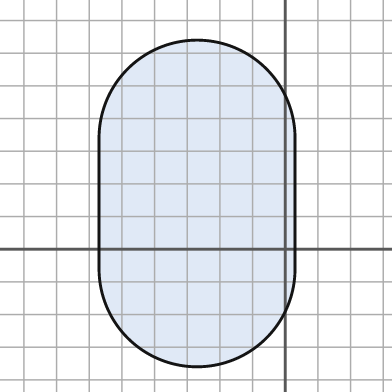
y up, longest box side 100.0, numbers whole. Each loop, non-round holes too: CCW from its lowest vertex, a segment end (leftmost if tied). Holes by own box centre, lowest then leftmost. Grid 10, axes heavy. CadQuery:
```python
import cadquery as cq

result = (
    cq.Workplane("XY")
    .moveTo(-57.0, -6.0)
    .threePointArc((-27.0, -36.0), (3.0, -6.0))
    .lineTo(3.0, 34.0)
    .threePointArc((-27.0, 64.0), (-57.0, 34.0))
    .close()
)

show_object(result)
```